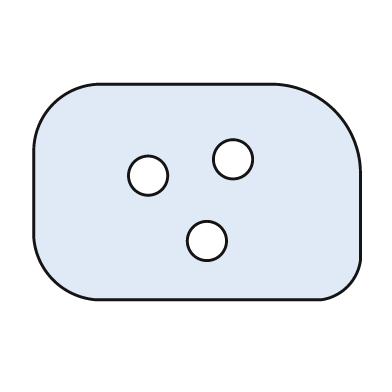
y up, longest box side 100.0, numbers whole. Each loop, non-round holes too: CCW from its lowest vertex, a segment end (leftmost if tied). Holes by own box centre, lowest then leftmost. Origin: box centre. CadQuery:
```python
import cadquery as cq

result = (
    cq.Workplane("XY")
    .moveTo(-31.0, -33.0)
    .lineTo(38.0, -33.0)
    .threePointArc((46.0, -29.0), (50.0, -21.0))
    .lineTo(50.0, 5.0)
    .threePointArc((42.0, 25.0), (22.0, 33.0))
    .lineTo(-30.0, 33.0)
    .threePointArc((-44.0, 27.0), (-50.0, 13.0))
    .lineTo(-50.0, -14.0)
    .threePointArc((-44.0, -27.0), (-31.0, -33.0))
    .close()
    .moveTo(3.0, -15.0)
    .circle(6.0)
    .moveTo(-15.0, 5.0)
    .circle(6.0)
    .moveTo(11.0, 10.0)
    .circle(6.0)
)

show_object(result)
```